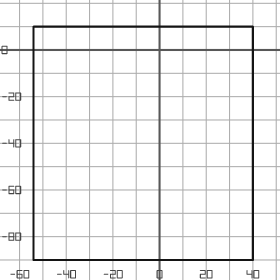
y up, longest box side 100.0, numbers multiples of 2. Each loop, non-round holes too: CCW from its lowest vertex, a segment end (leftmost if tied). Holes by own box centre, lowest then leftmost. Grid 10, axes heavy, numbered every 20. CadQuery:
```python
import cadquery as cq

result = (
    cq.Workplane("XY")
    .moveTo(-54.0, -90.0)
    .lineTo(40.0, -90.0)
    .lineTo(40.0, 10.0)
    .lineTo(-54.0, 10.0)
    .close()
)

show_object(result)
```